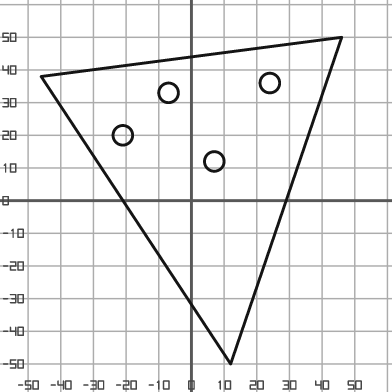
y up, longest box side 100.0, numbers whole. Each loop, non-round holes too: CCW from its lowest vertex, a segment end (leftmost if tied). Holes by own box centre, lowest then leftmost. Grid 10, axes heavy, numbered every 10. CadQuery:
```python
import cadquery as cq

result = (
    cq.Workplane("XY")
    .moveTo(12.0, -50.0)
    .lineTo(46.0, 50.0)
    .lineTo(-46.0, 38.0)
    .close()
    .moveTo(7.0, 12.0)
    .circle(3.0)
    .moveTo(-21.0, 20.0)
    .circle(3.0)
    .moveTo(-7.0, 33.0)
    .circle(3.0)
    .moveTo(24.0, 36.0)
    .circle(3.0)
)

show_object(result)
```